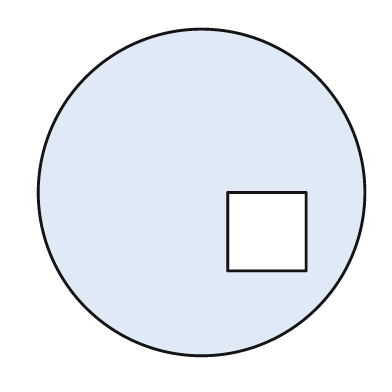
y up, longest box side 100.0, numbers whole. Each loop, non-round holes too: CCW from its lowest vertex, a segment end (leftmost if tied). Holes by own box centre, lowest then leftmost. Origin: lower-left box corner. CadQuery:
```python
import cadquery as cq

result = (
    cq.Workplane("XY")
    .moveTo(50.0, 50.0)
    .circle(50.0)
    .moveTo(58.0, 26.0)
    .lineTo(82.0, 26.0)
    .lineTo(82.0, 50.0)
    .lineTo(58.0, 50.0)
    .close()
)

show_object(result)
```